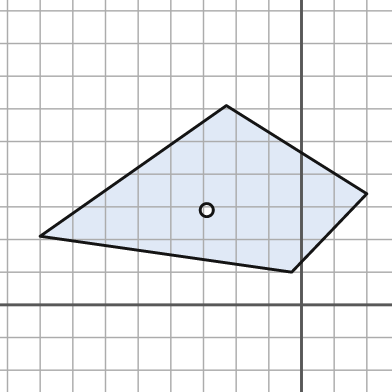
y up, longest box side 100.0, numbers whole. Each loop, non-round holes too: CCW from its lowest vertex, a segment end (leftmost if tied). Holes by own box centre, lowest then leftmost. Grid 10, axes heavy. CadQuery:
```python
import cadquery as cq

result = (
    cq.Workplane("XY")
    .moveTo(-3.0, 10.0)
    .lineTo(20.0, 34.0)
    .lineTo(-23.0, 61.0)
    .lineTo(-80.0, 21.0)
    .close()
    .moveTo(-29.0, 29.0)
    .circle(2.0)
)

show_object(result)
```